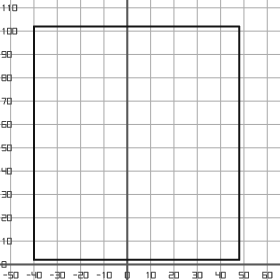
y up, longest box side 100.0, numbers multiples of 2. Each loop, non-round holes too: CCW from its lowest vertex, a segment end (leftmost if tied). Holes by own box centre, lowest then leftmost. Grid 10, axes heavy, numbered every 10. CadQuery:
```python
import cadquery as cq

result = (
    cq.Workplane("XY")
    .moveTo(-40.0, 2.0)
    .lineTo(48.0, 2.0)
    .lineTo(48.0, 102.0)
    .lineTo(-40.0, 102.0)
    .close()
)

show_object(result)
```